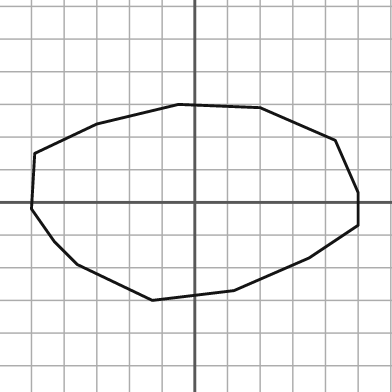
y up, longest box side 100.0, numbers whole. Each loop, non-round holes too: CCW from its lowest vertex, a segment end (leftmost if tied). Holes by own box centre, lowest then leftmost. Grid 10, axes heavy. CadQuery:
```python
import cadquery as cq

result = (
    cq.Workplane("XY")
    .moveTo(-13.0, -30.0)
    .lineTo(12.0, -27.0)
    .lineTo(35.0, -17.0)
    .lineTo(50.0, -7.0)
    .lineTo(50.0, 3.0)
    .lineTo(43.0, 19.0)
    .lineTo(20.0, 29.0)
    .lineTo(-5.0, 30.0)
    .lineTo(-30.0, 24.0)
    .lineTo(-49.0, 15.0)
    .lineTo(-50.0, -2.0)
    .lineTo(-43.0, -12.0)
    .lineTo(-36.0, -19.0)
    .close()
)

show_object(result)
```